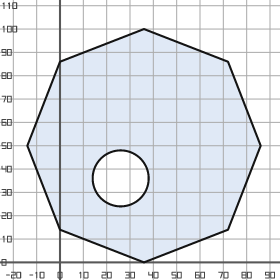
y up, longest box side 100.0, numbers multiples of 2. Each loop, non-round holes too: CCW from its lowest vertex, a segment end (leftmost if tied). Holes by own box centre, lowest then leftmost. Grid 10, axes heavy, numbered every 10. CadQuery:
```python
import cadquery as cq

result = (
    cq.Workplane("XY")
    .moveTo(36.0, 0.0)
    .lineTo(72.0, 14.0)
    .lineTo(86.0, 50.0)
    .lineTo(72.0, 86.0)
    .lineTo(36.0, 100.0)
    .lineTo(0.0, 86.0)
    .lineTo(-14.0, 50.0)
    .lineTo(0.0, 14.0)
    .close()
    .moveTo(26.0, 36.0)
    .circle(12.0)
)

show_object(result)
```